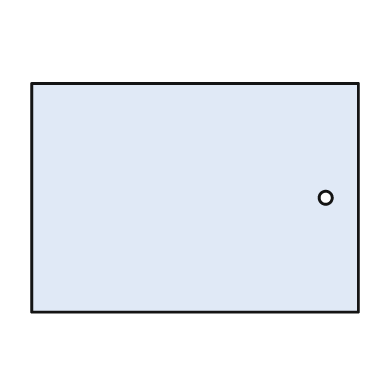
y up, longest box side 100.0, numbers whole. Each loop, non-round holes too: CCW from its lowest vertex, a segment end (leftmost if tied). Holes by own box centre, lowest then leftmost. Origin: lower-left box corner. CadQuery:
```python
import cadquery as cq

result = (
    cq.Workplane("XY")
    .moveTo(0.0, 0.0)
    .lineTo(100.0, 0.0)
    .lineTo(100.0, 70.0)
    .lineTo(0.0, 70.0)
    .close()
    .moveTo(90.0, 35.0)
    .circle(2.0)
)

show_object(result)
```